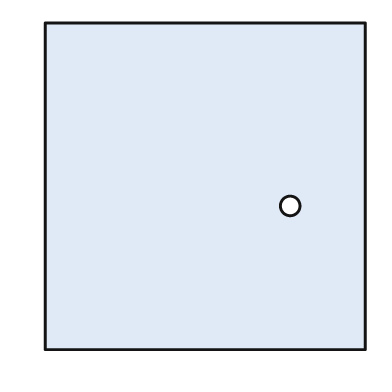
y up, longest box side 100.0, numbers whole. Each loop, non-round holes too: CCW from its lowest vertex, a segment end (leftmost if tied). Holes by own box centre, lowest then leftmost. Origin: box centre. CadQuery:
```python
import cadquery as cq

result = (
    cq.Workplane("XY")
    .moveTo(-49.0, -50.0)
    .lineTo(49.0, -50.0)
    .lineTo(49.0, 50.0)
    .lineTo(-49.0, 50.0)
    .close()
    .moveTo(26.0, -6.0)
    .circle(3.0)
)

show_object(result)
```